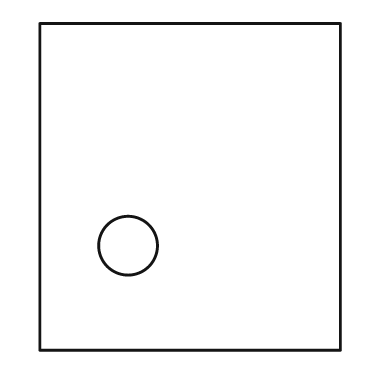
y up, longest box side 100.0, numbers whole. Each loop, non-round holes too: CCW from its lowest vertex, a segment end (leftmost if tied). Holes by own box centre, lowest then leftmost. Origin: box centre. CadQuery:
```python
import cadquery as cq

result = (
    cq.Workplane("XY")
    .moveTo(-46.0, -50.0)
    .lineTo(46.0, -50.0)
    .lineTo(46.0, 50.0)
    .lineTo(-46.0, 50.0)
    .close()
    .moveTo(-19.0, -18.0)
    .circle(9.0)
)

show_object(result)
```